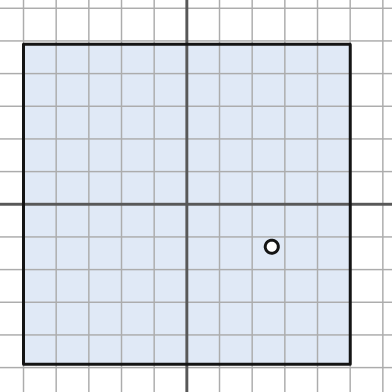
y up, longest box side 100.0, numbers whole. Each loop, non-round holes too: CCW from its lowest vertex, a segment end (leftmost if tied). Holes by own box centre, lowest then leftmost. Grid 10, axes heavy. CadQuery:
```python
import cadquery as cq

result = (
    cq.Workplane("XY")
    .moveTo(-50.0, -49.0)
    .lineTo(50.0, -49.0)
    .lineTo(50.0, 49.0)
    .lineTo(-50.0, 49.0)
    .close()
    .moveTo(26.0, -13.0)
    .circle(2.0)
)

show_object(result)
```